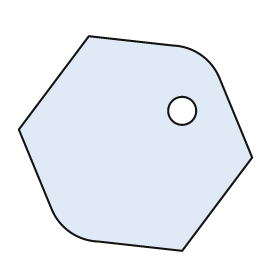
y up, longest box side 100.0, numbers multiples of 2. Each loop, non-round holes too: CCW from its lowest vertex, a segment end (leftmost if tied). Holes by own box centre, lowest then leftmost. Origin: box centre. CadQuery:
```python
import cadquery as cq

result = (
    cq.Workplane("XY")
    .moveTo(20.0, -46.0)
    .lineTo(50.0, -6.0)
    .lineTo(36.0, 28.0)
    .threePointArc((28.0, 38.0), (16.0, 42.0))
    .lineTo(-20.0, 46.0)
    .lineTo(-50.0, 6.0)
    .lineTo(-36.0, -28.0)
    .threePointArc((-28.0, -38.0), (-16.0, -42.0))
    .close()
    .moveTo(20.0, 14.0)
    .circle(6.0)
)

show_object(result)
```